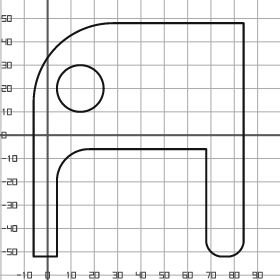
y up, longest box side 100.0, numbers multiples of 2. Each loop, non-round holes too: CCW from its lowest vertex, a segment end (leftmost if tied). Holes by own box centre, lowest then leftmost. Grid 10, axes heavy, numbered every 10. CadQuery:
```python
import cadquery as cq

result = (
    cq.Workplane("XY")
    .moveTo(-6.0, -52.0)
    .lineTo(4.0, -52.0)
    .lineTo(4.0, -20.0)
    .threePointArc((8.0, -10.0), (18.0, -6.0))
    .lineTo(68.0, -6.0)
    .lineTo(68.0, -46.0)
    .threePointArc((70.0, -50.0), (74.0, -52.0))
    .lineTo(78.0, -52.0)
    .threePointArc((82.0, -50.0), (84.0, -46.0))
    .lineTo(84.0, 48.0)
    .lineTo(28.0, 48.0)
    .threePointArc((4.0, 38.0), (-6.0, 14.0))
    .close()
    .moveTo(14.0, 20.0)
    .circle(10.0)
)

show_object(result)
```